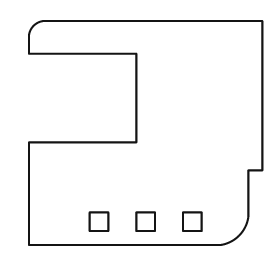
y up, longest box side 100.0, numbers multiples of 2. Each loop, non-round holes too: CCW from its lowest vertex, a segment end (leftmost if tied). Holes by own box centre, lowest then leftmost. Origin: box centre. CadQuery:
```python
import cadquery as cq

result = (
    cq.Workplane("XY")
    .moveTo(-50.0, -48.0)
    .lineTo(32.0, -48.0)
    .threePointArc((40.0, -44.0), (44.0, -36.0))
    .lineTo(44.0, -16.0)
    .lineTo(50.0, -16.0)
    .lineTo(50.0, 48.0)
    .lineTo(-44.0, 48.0)
    .threePointArc((-48.0, 46.0), (-50.0, 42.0))
    .lineTo(-50.0, 34.0)
    .lineTo(-4.0, 34.0)
    .lineTo(-4.0, -4.0)
    .lineTo(-50.0, -4.0)
    .close()
    .moveTo(-24.0, -42.0)
    .lineTo(-16.0, -42.0)
    .lineTo(-16.0, -34.0)
    .lineTo(-24.0, -34.0)
    .close()
    .moveTo(-4.0, -42.0)
    .lineTo(4.0, -42.0)
    .lineTo(4.0, -34.0)
    .lineTo(-4.0, -34.0)
    .close()
    .moveTo(16.0, -42.0)
    .lineTo(24.0, -42.0)
    .lineTo(24.0, -34.0)
    .lineTo(16.0, -34.0)
    .close()
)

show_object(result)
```